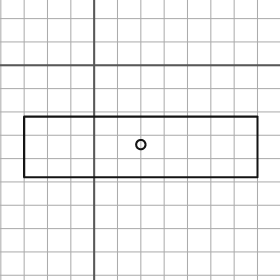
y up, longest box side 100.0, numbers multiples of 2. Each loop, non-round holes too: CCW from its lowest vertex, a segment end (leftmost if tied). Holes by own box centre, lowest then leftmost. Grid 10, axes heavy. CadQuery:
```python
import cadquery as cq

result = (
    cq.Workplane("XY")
    .moveTo(-30.0, -48.0)
    .lineTo(70.0, -48.0)
    .lineTo(70.0, -22.0)
    .lineTo(-30.0, -22.0)
    .close()
    .moveTo(20.0, -34.0)
    .circle(2.0)
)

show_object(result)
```